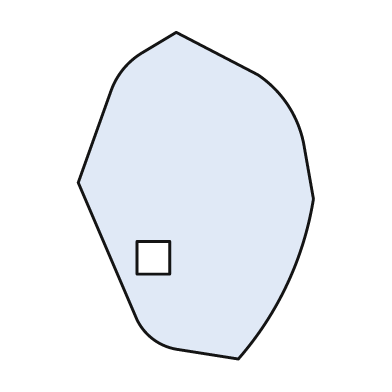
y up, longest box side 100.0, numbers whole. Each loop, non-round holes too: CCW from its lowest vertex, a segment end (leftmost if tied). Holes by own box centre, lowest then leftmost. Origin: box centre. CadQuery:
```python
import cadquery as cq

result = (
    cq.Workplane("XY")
    .moveTo(13.0, -50.0)
    .threePointArc((28.0, -27.0), (36.0, -1.0))
    .lineTo(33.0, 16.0)
    .threePointArc((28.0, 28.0), (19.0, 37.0))
    .lineTo(-6.0, 50.0)
    .lineTo(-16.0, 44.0)
    .threePointArc((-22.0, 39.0), (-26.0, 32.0))
    .lineTo(-36.0, 4.0)
    .lineTo(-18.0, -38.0)
    .threePointArc((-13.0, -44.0), (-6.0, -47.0))
    .close()
    .moveTo(-18.0, -24.0)
    .lineTo(-8.0, -24.0)
    .lineTo(-8.0, -14.0)
    .lineTo(-18.0, -14.0)
    .close()
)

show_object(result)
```